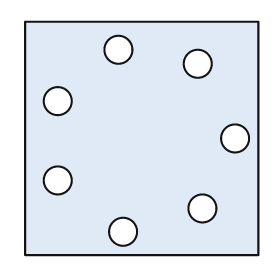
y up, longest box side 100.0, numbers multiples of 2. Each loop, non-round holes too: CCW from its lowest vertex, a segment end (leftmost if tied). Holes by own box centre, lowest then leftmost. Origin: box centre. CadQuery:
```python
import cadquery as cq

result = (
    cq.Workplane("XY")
    .moveTo(-50.0, -50.0)
    .lineTo(50.0, -50.0)
    .lineTo(50.0, 50.0)
    .lineTo(-50.0, 50.0)
    .close()
    .moveTo(-8.0, -40.0)
    .circle(6.0)
    .moveTo(26.0, -30.0)
    .circle(6.0)
    .moveTo(-36.0, -18.0)
    .circle(6.0)
    .moveTo(40.0, 0.0)
    .circle(6.0)
    .moveTo(-36.0, 16.0)
    .circle(6.0)
    .moveTo(24.0, 32.0)
    .circle(6.0)
    .moveTo(-10.0, 38.0)
    .circle(6.0)
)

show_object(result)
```